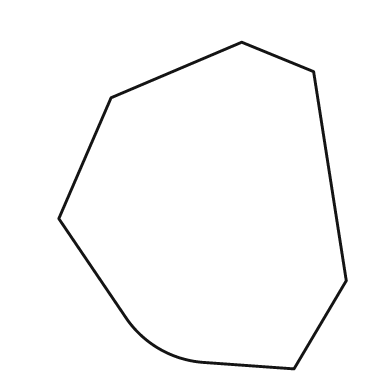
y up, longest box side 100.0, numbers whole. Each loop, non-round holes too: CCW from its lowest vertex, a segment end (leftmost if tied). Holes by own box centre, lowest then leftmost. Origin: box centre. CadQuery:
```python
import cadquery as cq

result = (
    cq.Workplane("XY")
    .moveTo(28.0, -50.0)
    .lineTo(44.0, -23.0)
    .lineTo(34.0, 41.0)
    .lineTo(12.0, 50.0)
    .lineTo(-28.0, 33.0)
    .lineTo(-44.0, -4.0)
    .lineTo(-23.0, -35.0)
    .threePointArc((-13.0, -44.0), (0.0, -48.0))
    .close()
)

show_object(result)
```